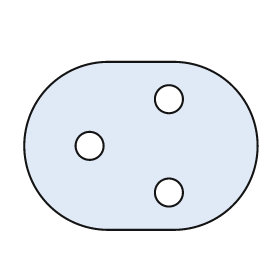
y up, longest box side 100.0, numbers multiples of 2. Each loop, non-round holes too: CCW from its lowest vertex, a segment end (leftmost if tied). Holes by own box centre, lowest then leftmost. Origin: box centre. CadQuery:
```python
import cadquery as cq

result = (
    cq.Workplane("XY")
    .moveTo(-14.0, -36.0)
    .lineTo(14.0, -36.0)
    .threePointArc((50.0, 0.0), (14.0, 36.0))
    .lineTo(-14.0, 36.0)
    .threePointArc((-50.0, 0.0), (-14.0, -36.0))
    .close()
    .moveTo(12.0, -20.0)
    .circle(6.0)
    .moveTo(-22.0, 0.0)
    .circle(6.0)
    .moveTo(12.0, 20.0)
    .circle(6.0)
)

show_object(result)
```